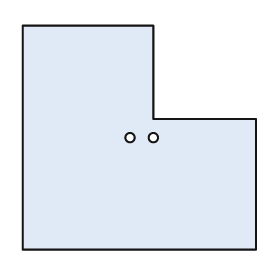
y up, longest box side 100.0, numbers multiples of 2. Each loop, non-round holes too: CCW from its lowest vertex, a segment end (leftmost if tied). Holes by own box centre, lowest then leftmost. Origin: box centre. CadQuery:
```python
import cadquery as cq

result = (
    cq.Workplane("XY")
    .moveTo(-50.0, -48.0)
    .lineTo(50.0, -48.0)
    .lineTo(50.0, 8.0)
    .lineTo(6.0, 8.0)
    .lineTo(6.0, 48.0)
    .lineTo(-50.0, 48.0)
    .close()
    .moveTo(-4.0, 0.0)
    .circle(2.0)
    .moveTo(6.0, 0.0)
    .circle(2.0)
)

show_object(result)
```